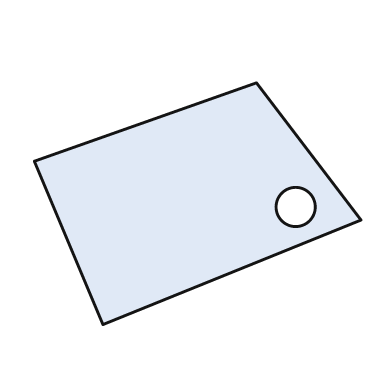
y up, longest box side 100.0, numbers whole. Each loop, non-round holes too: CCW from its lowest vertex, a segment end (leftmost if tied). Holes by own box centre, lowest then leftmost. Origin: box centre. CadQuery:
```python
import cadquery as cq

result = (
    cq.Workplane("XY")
    .moveTo(-29.0, -37.0)
    .lineTo(50.0, -5.0)
    .lineTo(18.0, 37.0)
    .lineTo(-50.0, 13.0)
    .close()
    .moveTo(30.0, -1.0)
    .circle(6.0)
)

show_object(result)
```